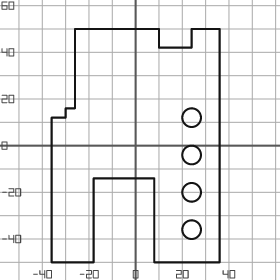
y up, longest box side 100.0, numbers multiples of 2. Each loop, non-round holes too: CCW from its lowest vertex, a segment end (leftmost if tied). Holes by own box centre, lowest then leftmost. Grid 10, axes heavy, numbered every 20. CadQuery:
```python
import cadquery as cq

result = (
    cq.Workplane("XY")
    .moveTo(-36.0, -50.0)
    .lineTo(-18.0, -50.0)
    .lineTo(-18.0, -14.0)
    .lineTo(8.0, -14.0)
    .lineTo(8.0, -50.0)
    .lineTo(36.0, -50.0)
    .lineTo(36.0, 50.0)
    .lineTo(24.0, 50.0)
    .lineTo(24.0, 42.0)
    .lineTo(10.0, 42.0)
    .lineTo(10.0, 50.0)
    .lineTo(-26.0, 50.0)
    .lineTo(-26.0, 16.0)
    .lineTo(-30.0, 16.0)
    .lineTo(-30.0, 12.0)
    .lineTo(-36.0, 12.0)
    .close()
    .moveTo(24.0, -36.0)
    .circle(4.0)
    .moveTo(24.0, -20.0)
    .circle(4.0)
    .moveTo(24.0, -4.0)
    .circle(4.0)
    .moveTo(24.0, 12.0)
    .circle(4.0)
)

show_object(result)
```